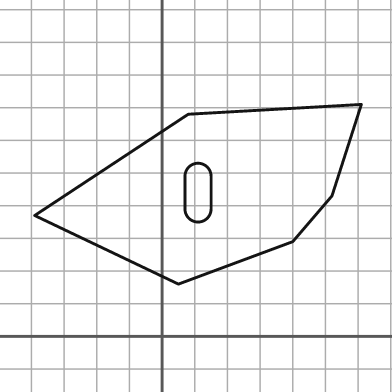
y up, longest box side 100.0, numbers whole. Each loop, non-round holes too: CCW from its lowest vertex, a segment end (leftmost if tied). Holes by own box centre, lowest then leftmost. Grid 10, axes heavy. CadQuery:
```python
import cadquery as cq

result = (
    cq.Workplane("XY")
    .moveTo(5.0, 16.0)
    .lineTo(40.0, 29.0)
    .lineTo(52.0, 43.0)
    .lineTo(61.0, 71.0)
    .lineTo(8.0, 68.0)
    .lineTo(-39.0, 37.0)
    .close()
    .moveTo(7.0, 39.0)
    .threePointArc((11.0, 35.0), (15.0, 39.0))
    .lineTo(15.0, 49.0)
    .threePointArc((11.0, 53.0), (7.0, 49.0))
    .close()
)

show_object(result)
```